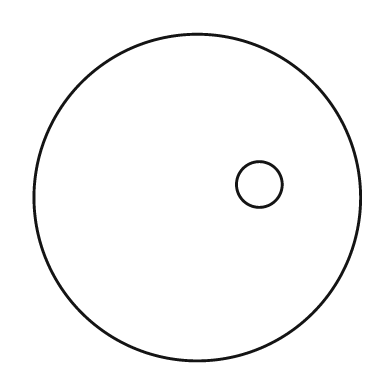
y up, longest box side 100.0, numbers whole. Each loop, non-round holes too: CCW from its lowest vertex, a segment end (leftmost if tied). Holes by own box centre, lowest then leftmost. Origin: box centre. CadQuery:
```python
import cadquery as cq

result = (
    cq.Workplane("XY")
    .moveTo(0.0, 0.0)
    .circle(50.0)
    .moveTo(19.0, 4.0)
    .circle(7.0)
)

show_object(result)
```